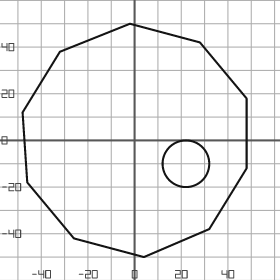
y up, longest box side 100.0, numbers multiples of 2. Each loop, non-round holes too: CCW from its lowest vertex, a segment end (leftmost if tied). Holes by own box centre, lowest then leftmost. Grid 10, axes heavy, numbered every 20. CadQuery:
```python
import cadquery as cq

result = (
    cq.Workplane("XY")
    .moveTo(4.0, -50.0)
    .lineTo(32.0, -38.0)
    .lineTo(48.0, -12.0)
    .lineTo(48.0, 18.0)
    .lineTo(28.0, 42.0)
    .lineTo(-2.0, 50.0)
    .lineTo(-32.0, 38.0)
    .lineTo(-48.0, 12.0)
    .lineTo(-46.0, -18.0)
    .lineTo(-26.0, -42.0)
    .close()
    .moveTo(22.0, -10.0)
    .circle(10.0)
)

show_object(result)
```